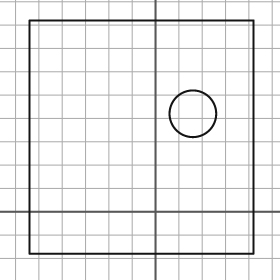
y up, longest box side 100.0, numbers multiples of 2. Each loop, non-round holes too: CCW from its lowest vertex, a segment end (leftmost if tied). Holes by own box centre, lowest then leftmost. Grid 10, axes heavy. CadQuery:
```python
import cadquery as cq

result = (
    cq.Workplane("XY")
    .moveTo(-54.0, -18.0)
    .lineTo(42.0, -18.0)
    .lineTo(42.0, 82.0)
    .lineTo(-54.0, 82.0)
    .close()
    .moveTo(16.0, 42.0)
    .circle(10.0)
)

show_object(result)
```